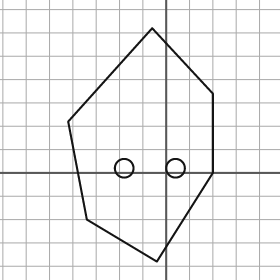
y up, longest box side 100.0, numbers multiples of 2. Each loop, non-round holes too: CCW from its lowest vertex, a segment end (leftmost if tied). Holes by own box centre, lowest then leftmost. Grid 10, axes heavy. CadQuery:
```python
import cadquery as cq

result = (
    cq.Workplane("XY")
    .moveTo(-4.0, -38.0)
    .lineTo(20.0, 0.0)
    .lineTo(20.0, 34.0)
    .lineTo(-6.0, 62.0)
    .lineTo(-42.0, 22.0)
    .lineTo(-34.0, -20.0)
    .close()
    .moveTo(-18.0, 2.0)
    .circle(4.0)
    .moveTo(4.0, 2.0)
    .circle(4.0)
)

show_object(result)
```